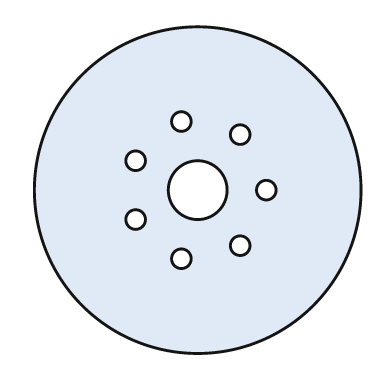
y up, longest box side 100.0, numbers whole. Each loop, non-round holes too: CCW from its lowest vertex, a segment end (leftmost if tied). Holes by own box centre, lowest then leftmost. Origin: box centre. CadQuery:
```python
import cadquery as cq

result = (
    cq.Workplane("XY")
    .moveTo(0.0, 0.0)
    .circle(50.0)
    .moveTo(-5.0, -21.0)
    .circle(3.0)
    .moveTo(13.0, -17.0)
    .circle(3.0)
    .moveTo(-19.0, -9.0)
    .circle(3.0)
    .moveTo(0.0, 0.0)
    .circle(9.0)
    .moveTo(21.0, 0.0)
    .circle(3.0)
    .moveTo(-19.0, 9.0)
    .circle(3.0)
    .moveTo(13.0, 17.0)
    .circle(3.0)
    .moveTo(-5.0, 21.0)
    .circle(3.0)
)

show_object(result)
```